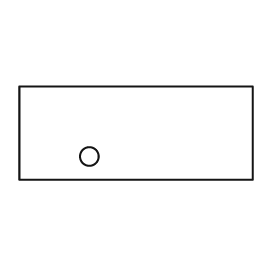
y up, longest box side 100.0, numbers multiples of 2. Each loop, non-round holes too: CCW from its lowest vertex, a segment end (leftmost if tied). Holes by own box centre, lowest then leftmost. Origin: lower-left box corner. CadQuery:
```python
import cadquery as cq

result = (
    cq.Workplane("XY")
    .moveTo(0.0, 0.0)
    .lineTo(100.0, 0.0)
    .lineTo(100.0, 40.0)
    .lineTo(0.0, 40.0)
    .close()
    .moveTo(30.0, 10.0)
    .circle(4.0)
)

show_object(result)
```